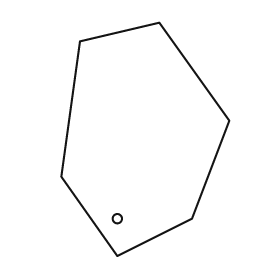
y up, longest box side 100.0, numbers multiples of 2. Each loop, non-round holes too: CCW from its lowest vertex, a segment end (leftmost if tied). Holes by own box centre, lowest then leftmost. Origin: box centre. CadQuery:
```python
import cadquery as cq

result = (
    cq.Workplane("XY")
    .moveTo(-12.0, -50.0)
    .lineTo(20.0, -34.0)
    .lineTo(36.0, 8.0)
    .lineTo(6.0, 50.0)
    .lineTo(-28.0, 42.0)
    .lineTo(-36.0, -16.0)
    .close()
    .moveTo(-12.0, -34.0)
    .circle(2.0)
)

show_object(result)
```